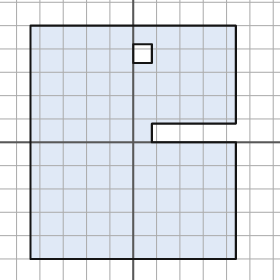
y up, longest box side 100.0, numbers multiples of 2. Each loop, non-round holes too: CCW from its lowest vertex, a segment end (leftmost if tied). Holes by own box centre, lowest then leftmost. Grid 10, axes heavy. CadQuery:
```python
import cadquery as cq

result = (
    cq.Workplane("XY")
    .moveTo(-44.0, -50.0)
    .lineTo(44.0, -50.0)
    .lineTo(44.0, 0.0)
    .lineTo(8.0, 0.0)
    .lineTo(8.0, 8.0)
    .lineTo(44.0, 8.0)
    .lineTo(44.0, 50.0)
    .lineTo(-44.0, 50.0)
    .close()
    .moveTo(0.0, 34.0)
    .lineTo(8.0, 34.0)
    .lineTo(8.0, 42.0)
    .lineTo(0.0, 42.0)
    .close()
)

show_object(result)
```